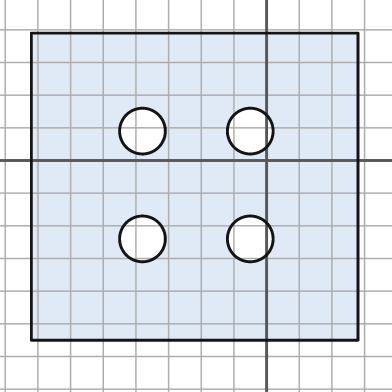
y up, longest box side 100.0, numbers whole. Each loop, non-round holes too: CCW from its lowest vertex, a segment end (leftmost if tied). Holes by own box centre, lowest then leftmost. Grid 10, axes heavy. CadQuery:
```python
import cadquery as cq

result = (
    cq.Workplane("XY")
    .moveTo(-72.0, -55.0)
    .lineTo(28.0, -55.0)
    .lineTo(28.0, 39.0)
    .lineTo(-72.0, 39.0)
    .close()
    .moveTo(-38.0, -24.0)
    .circle(7.0)
    .moveTo(-5.0, -24.0)
    .circle(7.0)
    .moveTo(-38.0, 9.0)
    .circle(7.0)
    .moveTo(-5.0, 9.0)
    .circle(7.0)
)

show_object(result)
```